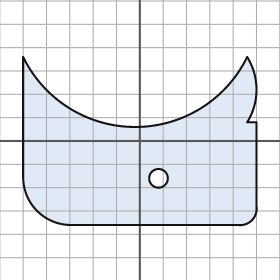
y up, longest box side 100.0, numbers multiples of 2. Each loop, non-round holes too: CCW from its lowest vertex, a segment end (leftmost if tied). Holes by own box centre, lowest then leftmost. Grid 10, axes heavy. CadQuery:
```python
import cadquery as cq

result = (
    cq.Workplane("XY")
    .moveTo(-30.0, -36.0)
    .lineTo(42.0, -36.0)
    .threePointArc((48.0, -34.0), (50.0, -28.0))
    .lineTo(50.0, 8.0)
    .lineTo(46.0, 8.0)
    .threePointArc((50.0, 22.0), (46.0, 36.0))
    .threePointArc((-2.0, 6.0), (-50.0, 36.0))
    .lineTo(-50.0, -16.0)
    .threePointArc((-44.0, -30.0), (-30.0, -36.0))
    .close()
    .moveTo(8.0, -16.0)
    .circle(4.0)
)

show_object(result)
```